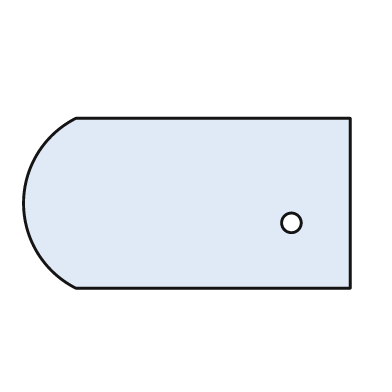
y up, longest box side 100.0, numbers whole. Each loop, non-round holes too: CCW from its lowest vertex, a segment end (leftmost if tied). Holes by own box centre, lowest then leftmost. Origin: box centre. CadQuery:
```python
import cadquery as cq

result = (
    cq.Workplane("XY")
    .moveTo(-34.0, -26.0)
    .lineTo(50.0, -26.0)
    .lineTo(50.0, 26.0)
    .lineTo(-34.0, 26.0)
    .threePointArc((-50.0, 0.0), (-34.0, -26.0))
    .close()
    .moveTo(32.0, -6.0)
    .circle(3.0)
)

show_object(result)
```